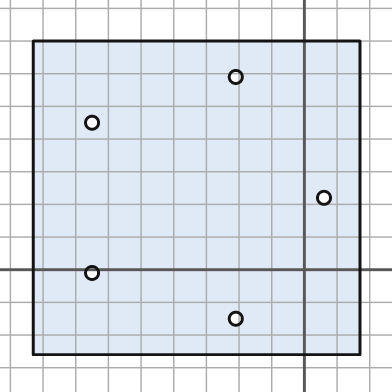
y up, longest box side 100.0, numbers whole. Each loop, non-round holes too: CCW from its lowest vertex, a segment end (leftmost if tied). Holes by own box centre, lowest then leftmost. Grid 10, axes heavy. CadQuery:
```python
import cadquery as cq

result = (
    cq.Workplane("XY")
    .moveTo(-83.0, -26.0)
    .lineTo(17.0, -26.0)
    .lineTo(17.0, 70.0)
    .lineTo(-83.0, 70.0)
    .close()
    .moveTo(-21.0, -15.0)
    .circle(2.0)
    .moveTo(-65.0, -1.0)
    .circle(2.0)
    .moveTo(6.0, 22.0)
    .circle(2.0)
    .moveTo(-65.0, 45.0)
    .circle(2.0)
    .moveTo(-21.0, 59.0)
    .circle(2.0)
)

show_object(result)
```